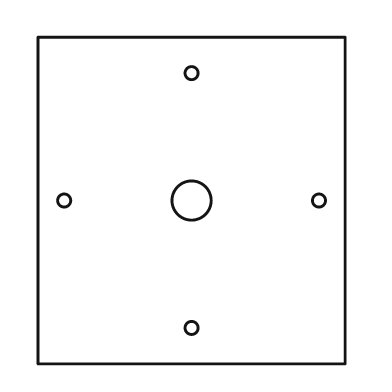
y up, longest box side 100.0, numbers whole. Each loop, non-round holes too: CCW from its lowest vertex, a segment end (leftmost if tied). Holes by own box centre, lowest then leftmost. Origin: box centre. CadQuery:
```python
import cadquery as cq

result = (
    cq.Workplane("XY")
    .moveTo(-47.0, -50.0)
    .lineTo(47.0, -50.0)
    .lineTo(47.0, 50.0)
    .lineTo(-47.0, 50.0)
    .close()
    .moveTo(0.0, -39.0)
    .circle(2.0)
    .moveTo(-39.0, 0.0)
    .circle(2.0)
    .moveTo(0.0, 0.0)
    .circle(6.0)
    .moveTo(39.0, 0.0)
    .circle(2.0)
    .moveTo(0.0, 39.0)
    .circle(2.0)
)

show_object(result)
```